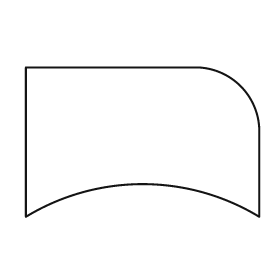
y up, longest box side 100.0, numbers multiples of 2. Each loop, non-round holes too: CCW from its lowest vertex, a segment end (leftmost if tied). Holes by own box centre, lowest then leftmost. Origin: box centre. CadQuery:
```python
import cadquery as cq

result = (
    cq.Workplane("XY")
    .moveTo(-50.0, -32.0)
    .threePointArc((0.0, -18.0), (50.0, -32.0))
    .lineTo(50.0, 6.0)
    .threePointArc((42.0, 24.0), (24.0, 32.0))
    .lineTo(-50.0, 32.0)
    .close()
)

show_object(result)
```